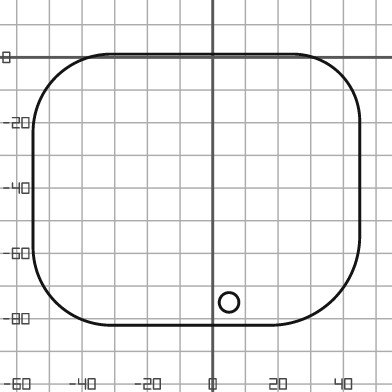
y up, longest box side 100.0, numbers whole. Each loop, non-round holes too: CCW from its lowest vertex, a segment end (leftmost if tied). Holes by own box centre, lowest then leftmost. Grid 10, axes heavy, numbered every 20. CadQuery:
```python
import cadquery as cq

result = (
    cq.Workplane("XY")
    .moveTo(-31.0, -82.0)
    .lineTo(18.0, -82.0)
    .threePointArc((37.0, -74.0), (45.0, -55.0))
    .lineTo(45.0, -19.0)
    .threePointArc((39.0, -5.0), (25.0, 1.0))
    .lineTo(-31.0, 1.0)
    .threePointArc((-48.0, -6.0), (-55.0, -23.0))
    .lineTo(-55.0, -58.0)
    .threePointArc((-48.0, -75.0), (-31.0, -82.0))
    .close()
    .moveTo(5.0, -75.0)
    .circle(3.0)
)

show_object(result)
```